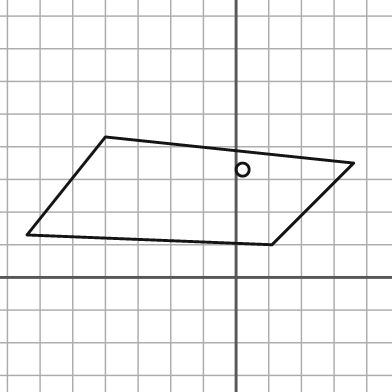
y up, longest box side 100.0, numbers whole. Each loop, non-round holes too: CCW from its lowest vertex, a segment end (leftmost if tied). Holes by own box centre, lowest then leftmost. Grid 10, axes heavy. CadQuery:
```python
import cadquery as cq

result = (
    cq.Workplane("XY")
    .moveTo(11.0, 10.0)
    .lineTo(36.0, 35.0)
    .lineTo(-40.0, 43.0)
    .lineTo(-64.0, 13.0)
    .close()
    .moveTo(2.0, 33.0)
    .circle(2.0)
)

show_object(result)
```